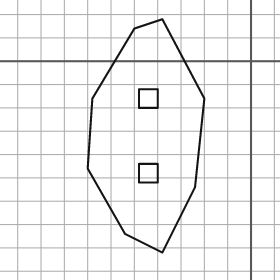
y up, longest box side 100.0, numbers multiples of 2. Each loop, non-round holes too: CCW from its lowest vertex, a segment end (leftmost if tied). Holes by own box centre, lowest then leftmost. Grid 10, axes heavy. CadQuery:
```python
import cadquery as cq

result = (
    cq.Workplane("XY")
    .moveTo(-38.0, -82.0)
    .lineTo(-24.0, -54.0)
    .lineTo(-20.0, -16.0)
    .lineTo(-38.0, 18.0)
    .lineTo(-50.0, 14.0)
    .lineTo(-68.0, -16.0)
    .lineTo(-70.0, -46.0)
    .lineTo(-54.0, -74.0)
    .close()
    .moveTo(-48.0, -52.0)
    .lineTo(-40.0, -52.0)
    .lineTo(-40.0, -44.0)
    .lineTo(-48.0, -44.0)
    .close()
    .moveTo(-48.0, -20.0)
    .lineTo(-40.0, -20.0)
    .lineTo(-40.0, -12.0)
    .lineTo(-48.0, -12.0)
    .close()
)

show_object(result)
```